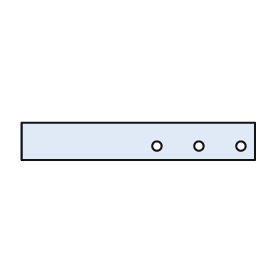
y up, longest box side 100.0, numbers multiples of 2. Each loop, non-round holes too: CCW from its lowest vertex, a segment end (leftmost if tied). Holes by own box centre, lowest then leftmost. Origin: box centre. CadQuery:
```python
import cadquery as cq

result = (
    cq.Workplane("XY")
    .moveTo(-50.0, -8.0)
    .lineTo(50.0, -8.0)
    .lineTo(50.0, 8.0)
    .lineTo(-50.0, 8.0)
    .close()
    .moveTo(8.0, -2.0)
    .circle(2.0)
    .moveTo(26.0, -2.0)
    .circle(2.0)
    .moveTo(44.0, -2.0)
    .circle(2.0)
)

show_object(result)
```